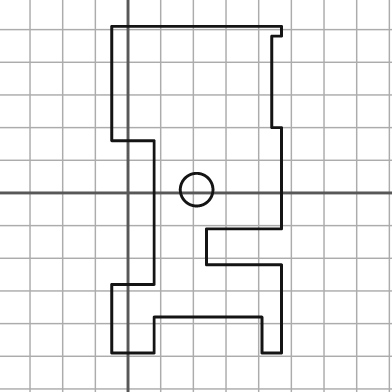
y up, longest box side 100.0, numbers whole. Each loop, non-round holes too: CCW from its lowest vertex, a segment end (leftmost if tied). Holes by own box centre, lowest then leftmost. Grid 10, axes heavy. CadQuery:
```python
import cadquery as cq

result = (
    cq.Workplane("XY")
    .moveTo(-5.0, -49.0)
    .lineTo(8.0, -49.0)
    .lineTo(8.0, -38.0)
    .lineTo(41.0, -38.0)
    .lineTo(41.0, -49.0)
    .lineTo(47.0, -49.0)
    .lineTo(47.0, -22.0)
    .lineTo(24.0, -22.0)
    .lineTo(24.0, -11.0)
    .lineTo(47.0, -11.0)
    .lineTo(47.0, 20.0)
    .lineTo(44.0, 20.0)
    .lineTo(44.0, 48.0)
    .lineTo(47.0, 48.0)
    .lineTo(47.0, 51.0)
    .lineTo(-5.0, 51.0)
    .lineTo(-5.0, 16.0)
    .lineTo(8.0, 16.0)
    .lineTo(8.0, -28.0)
    .lineTo(-5.0, -28.0)
    .close()
    .moveTo(21.0, 1.0)
    .circle(5.0)
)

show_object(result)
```